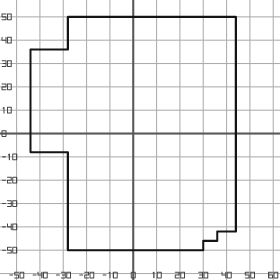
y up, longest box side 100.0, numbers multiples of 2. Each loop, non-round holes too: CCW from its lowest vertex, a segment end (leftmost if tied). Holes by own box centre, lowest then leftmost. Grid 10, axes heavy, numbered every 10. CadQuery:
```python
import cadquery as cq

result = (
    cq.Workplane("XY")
    .moveTo(-28.0, -50.0)
    .lineTo(30.0, -50.0)
    .lineTo(30.0, -46.0)
    .lineTo(36.0, -46.0)
    .lineTo(36.0, -42.0)
    .lineTo(44.0, -42.0)
    .lineTo(44.0, 50.0)
    .lineTo(-28.0, 50.0)
    .lineTo(-28.0, 36.0)
    .lineTo(-44.0, 36.0)
    .lineTo(-44.0, -8.0)
    .lineTo(-28.0, -8.0)
    .close()
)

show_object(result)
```